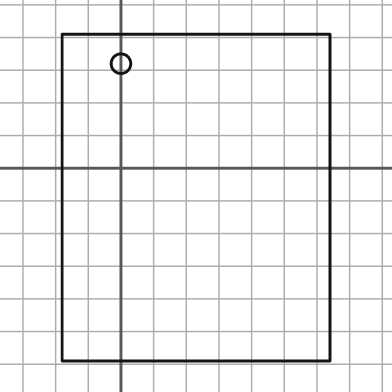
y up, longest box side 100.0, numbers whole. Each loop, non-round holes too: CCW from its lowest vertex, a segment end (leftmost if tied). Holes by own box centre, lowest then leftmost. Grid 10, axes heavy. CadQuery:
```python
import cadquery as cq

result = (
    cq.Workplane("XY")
    .moveTo(-18.0, -59.0)
    .lineTo(64.0, -59.0)
    .lineTo(64.0, 41.0)
    .lineTo(-18.0, 41.0)
    .close()
    .moveTo(0.0, 32.0)
    .circle(3.0)
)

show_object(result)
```